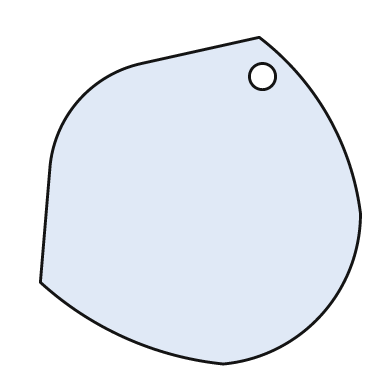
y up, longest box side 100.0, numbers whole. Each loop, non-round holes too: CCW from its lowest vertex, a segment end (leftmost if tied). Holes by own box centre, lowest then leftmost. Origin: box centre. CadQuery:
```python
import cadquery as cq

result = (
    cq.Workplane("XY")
    .moveTo(7.0, -50.0)
    .threePointArc((37.0, -35.0), (49.0, -4.0))
    .threePointArc((39.0, 26.0), (18.0, 50.0))
    .lineTo(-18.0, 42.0)
    .threePointArc((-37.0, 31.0), (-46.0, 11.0))
    .lineTo(-49.0, -25.0)
    .threePointArc((-23.0, -42.0), (7.0, -50.0))
    .close()
    .moveTo(19.0, 38.0)
    .circle(4.0)
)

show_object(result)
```